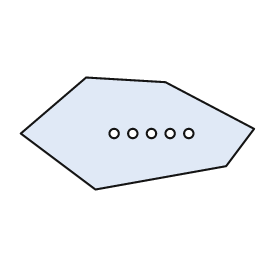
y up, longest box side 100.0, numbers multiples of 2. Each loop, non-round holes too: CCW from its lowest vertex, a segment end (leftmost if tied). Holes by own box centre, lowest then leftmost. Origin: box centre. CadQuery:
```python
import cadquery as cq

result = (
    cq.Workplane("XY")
    .moveTo(-18.0, -24.0)
    .lineTo(38.0, -14.0)
    .lineTo(50.0, 2.0)
    .lineTo(12.0, 22.0)
    .lineTo(-22.0, 24.0)
    .lineTo(-50.0, 0.0)
    .close()
    .moveTo(-10.0, 0.0)
    .circle(2.0)
    .moveTo(-2.0, 0.0)
    .circle(2.0)
    .moveTo(6.0, 0.0)
    .circle(2.0)
    .moveTo(14.0, 0.0)
    .circle(2.0)
    .moveTo(22.0, 0.0)
    .circle(2.0)
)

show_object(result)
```